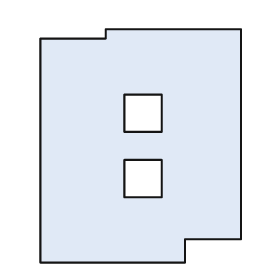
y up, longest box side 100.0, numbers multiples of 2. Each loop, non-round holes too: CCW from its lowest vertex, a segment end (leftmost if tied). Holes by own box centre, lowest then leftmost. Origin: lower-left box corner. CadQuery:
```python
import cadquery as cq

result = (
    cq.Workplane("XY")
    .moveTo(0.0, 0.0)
    .lineTo(62.0, 0.0)
    .lineTo(62.0, 10.0)
    .lineTo(86.0, 10.0)
    .lineTo(86.0, 100.0)
    .lineTo(28.0, 100.0)
    .lineTo(28.0, 96.0)
    .lineTo(0.0, 96.0)
    .close()
    .moveTo(36.0, 28.0)
    .lineTo(52.0, 28.0)
    .lineTo(52.0, 44.0)
    .lineTo(36.0, 44.0)
    .close()
    .moveTo(36.0, 56.0)
    .lineTo(52.0, 56.0)
    .lineTo(52.0, 72.0)
    .lineTo(36.0, 72.0)
    .close()
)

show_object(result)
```